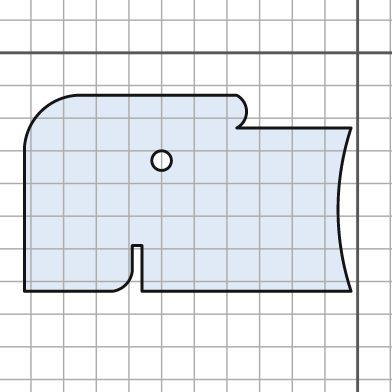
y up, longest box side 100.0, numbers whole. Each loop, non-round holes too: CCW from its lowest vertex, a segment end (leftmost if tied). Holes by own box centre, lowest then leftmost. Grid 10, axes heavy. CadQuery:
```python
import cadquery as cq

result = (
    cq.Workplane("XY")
    .moveTo(-102.0, -73.0)
    .lineTo(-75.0, -73.0)
    .threePointArc((-71.0, -71.0), (-69.0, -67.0))
    .lineTo(-69.0, -59.0)
    .lineTo(-66.0, -59.0)
    .lineTo(-66.0, -73.0)
    .lineTo(-2.0, -73.0)
    .threePointArc((-6.0, -48.0), (-2.0, -23.0))
    .lineTo(-37.0, -23.0)
    .threePointArc((-34.0, -18.0), (-37.0, -13.0))
    .lineTo(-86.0, -13.0)
    .threePointArc((-97.0, -18.0), (-102.0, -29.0))
    .close()
    .moveTo(-60.0, -33.0)
    .circle(3.0)
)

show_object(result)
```